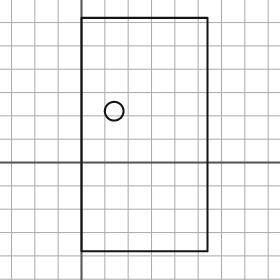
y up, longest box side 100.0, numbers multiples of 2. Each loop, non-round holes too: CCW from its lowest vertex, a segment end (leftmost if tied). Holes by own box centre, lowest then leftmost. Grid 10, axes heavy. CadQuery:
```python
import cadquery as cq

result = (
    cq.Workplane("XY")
    .moveTo(0.0, -38.0)
    .lineTo(54.0, -38.0)
    .lineTo(54.0, 62.0)
    .lineTo(0.0, 62.0)
    .close()
    .moveTo(14.0, 22.0)
    .circle(4.0)
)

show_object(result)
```